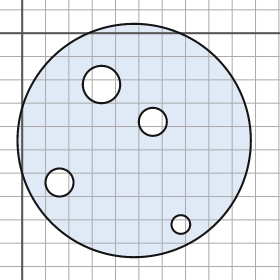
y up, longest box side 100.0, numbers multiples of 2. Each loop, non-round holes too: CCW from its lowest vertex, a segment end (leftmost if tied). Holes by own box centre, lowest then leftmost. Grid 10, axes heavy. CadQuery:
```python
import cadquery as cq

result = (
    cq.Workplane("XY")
    .moveTo(48.0, -46.0)
    .circle(50.0)
    .moveTo(68.0, -82.0)
    .circle(4.0)
    .moveTo(16.0, -64.0)
    .circle(6.0)
    .moveTo(56.0, -38.0)
    .circle(6.0)
    .moveTo(34.0, -22.0)
    .circle(8.0)
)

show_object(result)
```